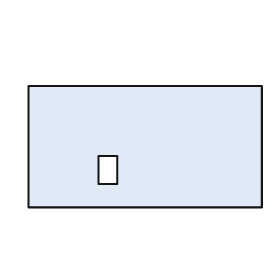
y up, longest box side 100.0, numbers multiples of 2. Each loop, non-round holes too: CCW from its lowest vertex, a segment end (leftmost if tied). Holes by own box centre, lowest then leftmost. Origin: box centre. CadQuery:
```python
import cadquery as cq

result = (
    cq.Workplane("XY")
    .moveTo(-50.0, -26.0)
    .lineTo(50.0, -26.0)
    .lineTo(50.0, 26.0)
    .lineTo(-50.0, 26.0)
    .close()
    .moveTo(-20.0, -16.0)
    .lineTo(-12.0, -16.0)
    .lineTo(-12.0, -4.0)
    .lineTo(-20.0, -4.0)
    .close()
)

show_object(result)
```